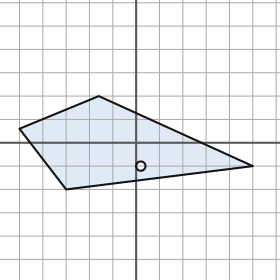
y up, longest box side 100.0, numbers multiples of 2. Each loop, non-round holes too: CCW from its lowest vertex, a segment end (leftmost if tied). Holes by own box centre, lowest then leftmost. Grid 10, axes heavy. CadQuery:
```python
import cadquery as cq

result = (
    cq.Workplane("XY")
    .moveTo(-30.0, -20.0)
    .lineTo(50.0, -10.0)
    .lineTo(-16.0, 20.0)
    .lineTo(-50.0, 6.0)
    .close()
    .moveTo(2.0, -10.0)
    .circle(2.0)
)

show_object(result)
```